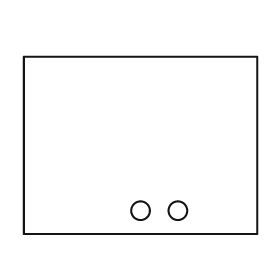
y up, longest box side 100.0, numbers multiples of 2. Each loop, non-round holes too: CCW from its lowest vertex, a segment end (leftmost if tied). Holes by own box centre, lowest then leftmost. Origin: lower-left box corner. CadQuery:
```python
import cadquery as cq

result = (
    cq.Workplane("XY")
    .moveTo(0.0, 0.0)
    .lineTo(100.0, 0.0)
    .lineTo(100.0, 76.0)
    .lineTo(0.0, 76.0)
    .close()
    .moveTo(50.0, 10.0)
    .circle(4.0)
    .moveTo(66.0, 10.0)
    .circle(4.0)
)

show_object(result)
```